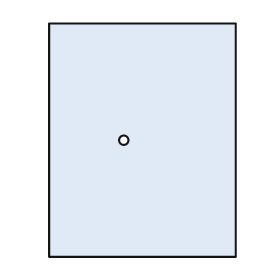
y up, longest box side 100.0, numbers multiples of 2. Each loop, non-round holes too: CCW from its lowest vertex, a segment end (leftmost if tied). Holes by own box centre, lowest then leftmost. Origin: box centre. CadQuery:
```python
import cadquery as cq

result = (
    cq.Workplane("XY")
    .moveTo(-40.0, -50.0)
    .lineTo(40.0, -50.0)
    .lineTo(40.0, 50.0)
    .lineTo(-40.0, 50.0)
    .close()
    .moveTo(-8.0, 0.0)
    .circle(2.0)
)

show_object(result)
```